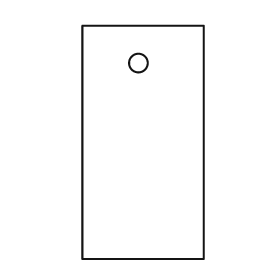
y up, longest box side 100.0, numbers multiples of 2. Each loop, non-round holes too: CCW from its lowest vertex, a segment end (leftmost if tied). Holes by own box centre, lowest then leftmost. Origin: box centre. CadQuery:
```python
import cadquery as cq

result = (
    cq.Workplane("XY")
    .moveTo(-26.0, -50.0)
    .lineTo(26.0, -50.0)
    .lineTo(26.0, 50.0)
    .lineTo(-26.0, 50.0)
    .close()
    .moveTo(-2.0, 34.0)
    .circle(4.0)
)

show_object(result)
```